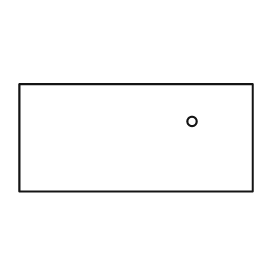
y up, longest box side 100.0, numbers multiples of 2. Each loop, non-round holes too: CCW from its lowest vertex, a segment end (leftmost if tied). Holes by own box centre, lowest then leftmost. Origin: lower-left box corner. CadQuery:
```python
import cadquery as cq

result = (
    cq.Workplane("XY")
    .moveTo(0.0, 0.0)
    .lineTo(100.0, 0.0)
    .lineTo(100.0, 46.0)
    .lineTo(0.0, 46.0)
    .close()
    .moveTo(74.0, 30.0)
    .circle(2.0)
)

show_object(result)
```